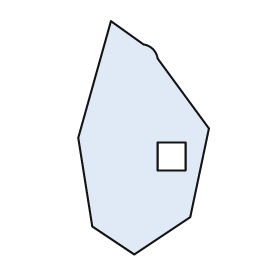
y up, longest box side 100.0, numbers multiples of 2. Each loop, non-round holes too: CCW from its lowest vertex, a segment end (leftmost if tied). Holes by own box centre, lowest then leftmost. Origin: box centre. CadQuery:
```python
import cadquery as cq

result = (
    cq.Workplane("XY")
    .moveTo(-4.0, -50.0)
    .lineTo(20.0, -34.0)
    .lineTo(28.0, 4.0)
    .lineTo(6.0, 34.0)
    .threePointArc((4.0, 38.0), (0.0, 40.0))
    .lineTo(-14.0, 50.0)
    .lineTo(-28.0, 0.0)
    .lineTo(-22.0, -38.0)
    .close()
    .moveTo(6.0, -14.0)
    .lineTo(18.0, -14.0)
    .lineTo(18.0, -2.0)
    .lineTo(6.0, -2.0)
    .close()
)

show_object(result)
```